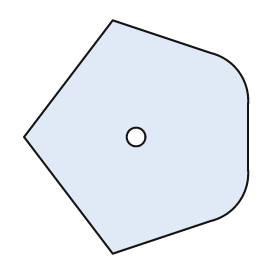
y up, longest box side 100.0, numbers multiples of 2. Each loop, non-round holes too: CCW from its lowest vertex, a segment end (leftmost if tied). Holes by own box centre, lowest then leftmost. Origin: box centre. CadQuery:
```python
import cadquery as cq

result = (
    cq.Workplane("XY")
    .moveTo(-10.0, -50.0)
    .lineTo(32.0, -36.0)
    .threePointArc((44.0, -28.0), (48.0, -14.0))
    .lineTo(48.0, 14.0)
    .threePointArc((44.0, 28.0), (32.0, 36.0))
    .lineTo(-10.0, 50.0)
    .lineTo(-48.0, 0.0)
    .close()
    .moveTo(0.0, 0.0)
    .circle(4.0)
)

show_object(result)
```